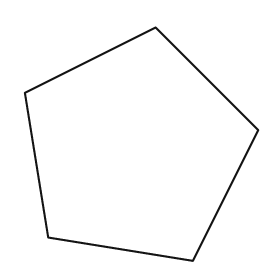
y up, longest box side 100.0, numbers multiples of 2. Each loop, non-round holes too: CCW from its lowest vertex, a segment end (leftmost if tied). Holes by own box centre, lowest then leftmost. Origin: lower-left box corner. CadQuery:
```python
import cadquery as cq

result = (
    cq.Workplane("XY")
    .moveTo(72.0, 0.0)
    .lineTo(100.0, 56.0)
    .lineTo(56.0, 100.0)
    .lineTo(0.0, 72.0)
    .lineTo(10.0, 10.0)
    .close()
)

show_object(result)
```